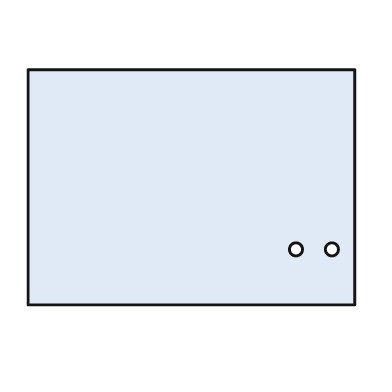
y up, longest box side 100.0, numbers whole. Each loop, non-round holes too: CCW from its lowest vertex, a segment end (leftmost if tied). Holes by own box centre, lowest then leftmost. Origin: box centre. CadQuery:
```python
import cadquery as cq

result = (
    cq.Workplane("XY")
    .moveTo(-50.0, -36.0)
    .lineTo(50.0, -36.0)
    .lineTo(50.0, 36.0)
    .lineTo(-50.0, 36.0)
    .close()
    .moveTo(32.0, -19.0)
    .circle(2.0)
    .moveTo(43.0, -19.0)
    .circle(2.0)
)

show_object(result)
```